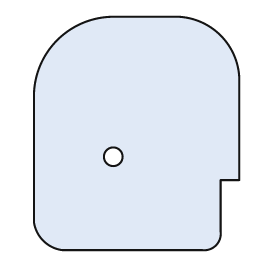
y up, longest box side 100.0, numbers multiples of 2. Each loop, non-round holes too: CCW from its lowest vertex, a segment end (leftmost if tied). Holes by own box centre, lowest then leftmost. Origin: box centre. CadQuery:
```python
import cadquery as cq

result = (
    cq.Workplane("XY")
    .moveTo(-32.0, -50.0)
    .lineTo(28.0, -50.0)
    .threePointArc((34.0, -48.0), (36.0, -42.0))
    .lineTo(36.0, -20.0)
    .lineTo(44.0, -20.0)
    .lineTo(44.0, 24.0)
    .threePointArc((36.0, 42.0), (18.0, 50.0))
    .lineTo(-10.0, 50.0)
    .threePointArc((-34.0, 40.0), (-44.0, 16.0))
    .lineTo(-44.0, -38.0)
    .threePointArc((-40.0, -46.0), (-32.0, -50.0))
    .close()
    .moveTo(-10.0, -10.0)
    .circle(4.0)
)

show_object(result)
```